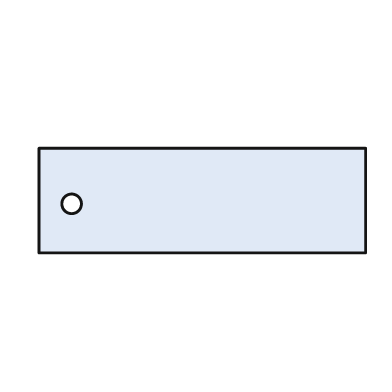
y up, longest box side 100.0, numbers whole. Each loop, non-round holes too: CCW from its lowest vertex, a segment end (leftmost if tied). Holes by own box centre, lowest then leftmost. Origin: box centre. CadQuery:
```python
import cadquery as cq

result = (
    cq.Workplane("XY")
    .moveTo(-50.0, -16.0)
    .lineTo(50.0, -16.0)
    .lineTo(50.0, 16.0)
    .lineTo(-50.0, 16.0)
    .close()
    .moveTo(-40.0, -1.0)
    .circle(3.0)
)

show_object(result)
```